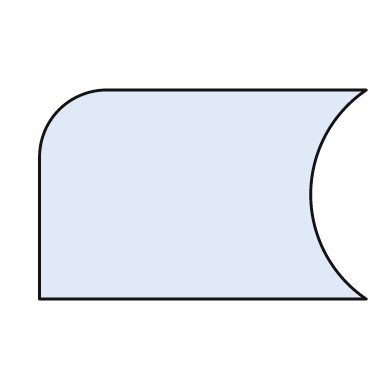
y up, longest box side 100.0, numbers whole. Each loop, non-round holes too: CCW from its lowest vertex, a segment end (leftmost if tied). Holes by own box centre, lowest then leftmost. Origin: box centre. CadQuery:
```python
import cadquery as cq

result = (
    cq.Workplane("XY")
    .moveTo(-50.0, -32.0)
    .lineTo(50.0, -32.0)
    .threePointArc((33.0, 0.0), (50.0, 32.0))
    .lineTo(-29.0, 32.0)
    .threePointArc((-44.0, 26.0), (-50.0, 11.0))
    .close()
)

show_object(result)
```